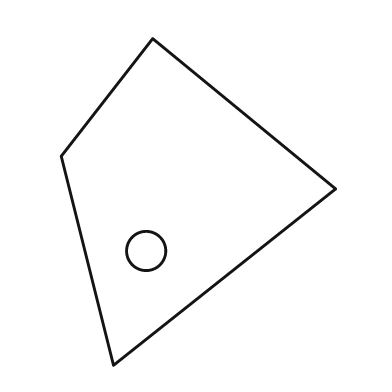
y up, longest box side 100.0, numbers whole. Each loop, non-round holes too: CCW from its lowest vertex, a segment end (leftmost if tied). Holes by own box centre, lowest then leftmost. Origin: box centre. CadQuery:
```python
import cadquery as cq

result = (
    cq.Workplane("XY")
    .moveTo(-26.0, -50.0)
    .lineTo(42.0, 4.0)
    .lineTo(-14.0, 50.0)
    .lineTo(-42.0, 14.0)
    .close()
    .moveTo(-16.0, -15.0)
    .circle(6.0)
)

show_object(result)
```